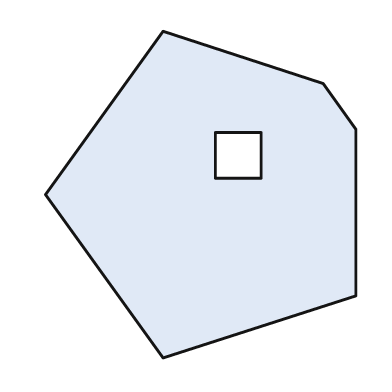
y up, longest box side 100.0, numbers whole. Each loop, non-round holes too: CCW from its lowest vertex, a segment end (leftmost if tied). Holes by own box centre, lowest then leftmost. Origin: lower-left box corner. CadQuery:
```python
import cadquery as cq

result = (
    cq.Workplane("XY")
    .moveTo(36.0, 0.0)
    .lineTo(95.0, 19.0)
    .lineTo(95.0, 70.0)
    .lineTo(85.0, 84.0)
    .lineTo(36.0, 100.0)
    .lineTo(0.0, 50.0)
    .close()
    .moveTo(52.0, 55.0)
    .lineTo(66.0, 55.0)
    .lineTo(66.0, 69.0)
    .lineTo(52.0, 69.0)
    .close()
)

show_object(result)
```